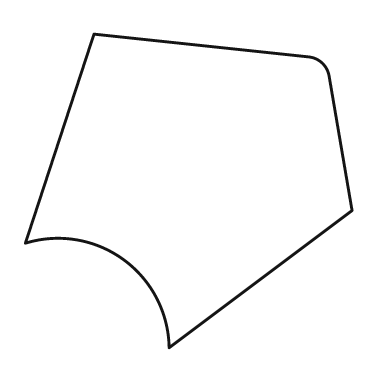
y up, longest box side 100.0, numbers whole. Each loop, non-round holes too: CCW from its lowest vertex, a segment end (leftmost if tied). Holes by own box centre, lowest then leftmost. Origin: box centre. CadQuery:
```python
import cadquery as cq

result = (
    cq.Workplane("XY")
    .moveTo(-6.0, -48.0)
    .lineTo(50.0, -6.0)
    .lineTo(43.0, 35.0)
    .threePointArc((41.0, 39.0), (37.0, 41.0))
    .lineTo(-29.0, 48.0)
    .lineTo(-50.0, -16.0)
    .threePointArc((-20.0, -21.0), (-6.0, -48.0))
    .close()
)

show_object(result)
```